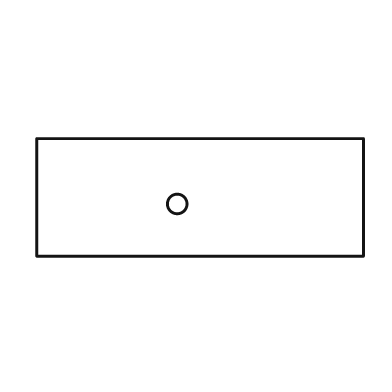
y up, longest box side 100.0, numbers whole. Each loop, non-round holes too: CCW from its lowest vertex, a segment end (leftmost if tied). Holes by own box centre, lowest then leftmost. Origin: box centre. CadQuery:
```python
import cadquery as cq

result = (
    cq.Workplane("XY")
    .moveTo(-50.0, -18.0)
    .lineTo(50.0, -18.0)
    .lineTo(50.0, 18.0)
    .lineTo(-50.0, 18.0)
    .close()
    .moveTo(-7.0, -2.0)
    .circle(3.0)
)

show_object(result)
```